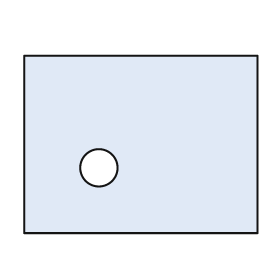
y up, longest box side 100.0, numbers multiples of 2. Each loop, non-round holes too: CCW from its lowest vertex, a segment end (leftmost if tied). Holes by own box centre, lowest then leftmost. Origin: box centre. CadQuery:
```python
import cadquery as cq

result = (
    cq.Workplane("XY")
    .moveTo(-50.0, -38.0)
    .lineTo(50.0, -38.0)
    .lineTo(50.0, 38.0)
    .lineTo(-50.0, 38.0)
    .close()
    .moveTo(-18.0, -10.0)
    .circle(8.0)
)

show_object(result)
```